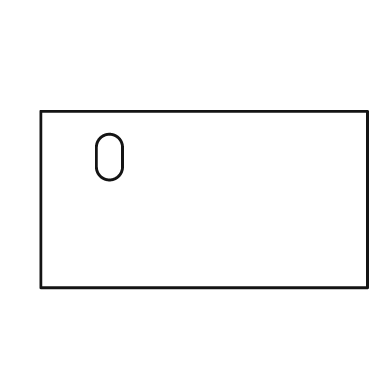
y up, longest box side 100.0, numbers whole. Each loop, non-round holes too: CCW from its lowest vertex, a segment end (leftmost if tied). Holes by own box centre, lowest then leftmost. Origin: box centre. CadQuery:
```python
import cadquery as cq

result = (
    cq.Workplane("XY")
    .moveTo(-50.0, -27.0)
    .lineTo(50.0, -27.0)
    .lineTo(50.0, 27.0)
    .lineTo(-50.0, 27.0)
    .close()
    .moveTo(-33.0, 10.0)
    .threePointArc((-29.0, 6.0), (-25.0, 10.0))
    .lineTo(-25.0, 16.0)
    .threePointArc((-29.0, 20.0), (-33.0, 16.0))
    .close()
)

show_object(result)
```